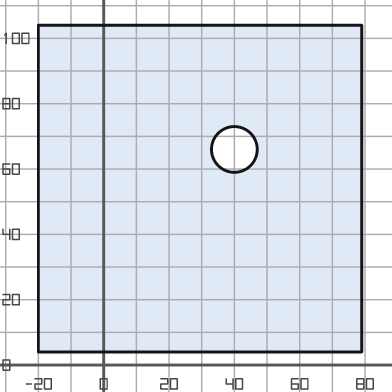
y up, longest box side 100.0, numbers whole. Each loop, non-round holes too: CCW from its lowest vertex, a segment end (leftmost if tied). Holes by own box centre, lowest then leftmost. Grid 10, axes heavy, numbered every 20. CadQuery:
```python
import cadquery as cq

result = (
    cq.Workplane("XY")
    .moveTo(-20.0, 4.0)
    .lineTo(79.0, 4.0)
    .lineTo(79.0, 104.0)
    .lineTo(-20.0, 104.0)
    .close()
    .moveTo(40.0, 66.0)
    .circle(7.0)
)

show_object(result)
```